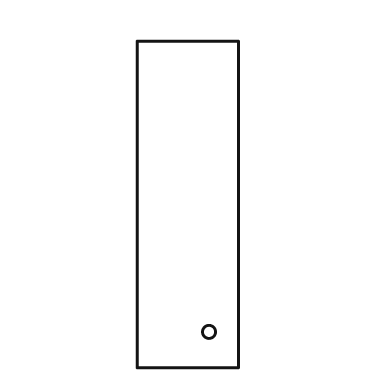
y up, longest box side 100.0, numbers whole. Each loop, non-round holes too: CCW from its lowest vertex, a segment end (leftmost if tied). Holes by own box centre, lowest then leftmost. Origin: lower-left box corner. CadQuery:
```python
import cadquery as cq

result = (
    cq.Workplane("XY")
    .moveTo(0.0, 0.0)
    .lineTo(31.0, 0.0)
    .lineTo(31.0, 100.0)
    .lineTo(0.0, 100.0)
    .close()
    .moveTo(22.0, 11.0)
    .circle(2.0)
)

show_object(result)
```